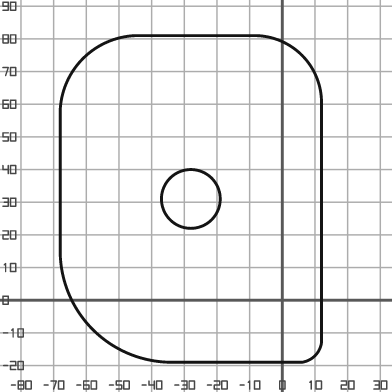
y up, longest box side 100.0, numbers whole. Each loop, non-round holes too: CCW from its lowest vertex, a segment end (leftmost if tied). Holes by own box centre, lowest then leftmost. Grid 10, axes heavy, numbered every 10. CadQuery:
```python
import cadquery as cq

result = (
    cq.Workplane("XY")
    .moveTo(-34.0, -19.0)
    .lineTo(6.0, -19.0)
    .threePointArc((10.0, -17.0), (12.0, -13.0))
    .lineTo(12.0, 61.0)
    .threePointArc((6.0, 75.0), (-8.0, 81.0))
    .lineTo(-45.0, 81.0)
    .threePointArc((-61.0, 74.0), (-68.0, 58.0))
    .lineTo(-68.0, 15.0)
    .threePointArc((-58.0, -9.0), (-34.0, -19.0))
    .close()
    .moveTo(-28.0, 31.0)
    .circle(9.0)
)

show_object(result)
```